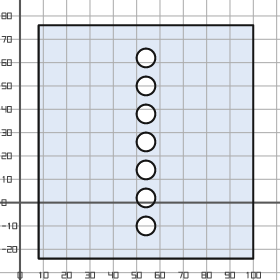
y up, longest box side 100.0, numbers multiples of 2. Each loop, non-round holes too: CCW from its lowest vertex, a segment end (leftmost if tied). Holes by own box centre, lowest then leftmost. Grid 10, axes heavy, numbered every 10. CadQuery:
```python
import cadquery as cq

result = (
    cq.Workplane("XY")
    .moveTo(8.0, -24.0)
    .lineTo(100.0, -24.0)
    .lineTo(100.0, 76.0)
    .lineTo(8.0, 76.0)
    .close()
    .moveTo(54.0, -10.0)
    .circle(4.0)
    .moveTo(54.0, 2.0)
    .circle(4.0)
    .moveTo(54.0, 14.0)
    .circle(4.0)
    .moveTo(54.0, 26.0)
    .circle(4.0)
    .moveTo(54.0, 38.0)
    .circle(4.0)
    .moveTo(54.0, 50.0)
    .circle(4.0)
    .moveTo(54.0, 62.0)
    .circle(4.0)
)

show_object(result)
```